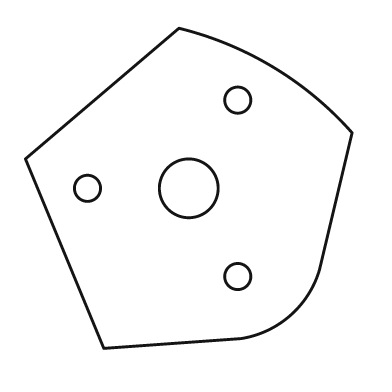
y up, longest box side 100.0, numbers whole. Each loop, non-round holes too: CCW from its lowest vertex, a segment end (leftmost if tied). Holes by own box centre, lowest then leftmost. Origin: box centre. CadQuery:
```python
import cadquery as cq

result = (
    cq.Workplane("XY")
    .moveTo(-26.0, -49.0)
    .lineTo(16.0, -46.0)
    .threePointArc((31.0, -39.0), (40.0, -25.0))
    .lineTo(50.0, 17.0)
    .threePointArc((26.0, 37.0), (-3.0, 49.0))
    .lineTo(-50.0, 9.0)
    .close()
    .moveTo(15.0, -27.0)
    .circle(4.0)
    .moveTo(-31.0, 0.0)
    .circle(4.0)
    .moveTo(0.0, 0.0)
    .circle(9.0)
    .moveTo(15.0, 27.0)
    .circle(4.0)
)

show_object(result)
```